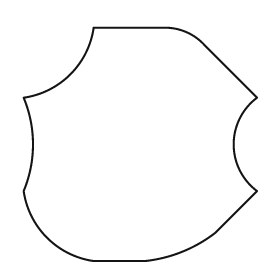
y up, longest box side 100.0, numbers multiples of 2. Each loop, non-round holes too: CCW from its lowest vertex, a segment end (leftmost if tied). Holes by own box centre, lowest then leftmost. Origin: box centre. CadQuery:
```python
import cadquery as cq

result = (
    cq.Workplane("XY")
    .moveTo(-20.0, -50.0)
    .lineTo(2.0, -50.0)
    .threePointArc((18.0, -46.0), (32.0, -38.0))
    .lineTo(50.0, -20.0)
    .threePointArc((40.0, 0.0), (50.0, 20.0))
    .lineTo(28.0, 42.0)
    .threePointArc((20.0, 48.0), (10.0, 50.0))
    .lineTo(-20.0, 50.0)
    .threePointArc((-30.0, 30.0), (-50.0, 20.0))
    .threePointArc((-46.0, 0.0), (-50.0, -20.0))
    .threePointArc((-40.0, -40.0), (-20.0, -50.0))
    .close()
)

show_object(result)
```